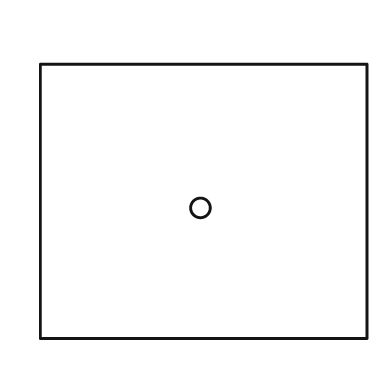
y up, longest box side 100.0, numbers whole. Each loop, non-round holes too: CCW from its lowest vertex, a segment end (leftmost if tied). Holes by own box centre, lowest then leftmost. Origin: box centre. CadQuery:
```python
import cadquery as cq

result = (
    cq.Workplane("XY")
    .moveTo(-50.0, -42.0)
    .lineTo(50.0, -42.0)
    .lineTo(50.0, 42.0)
    .lineTo(-50.0, 42.0)
    .close()
    .moveTo(-1.0, -2.0)
    .circle(3.0)
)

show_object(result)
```